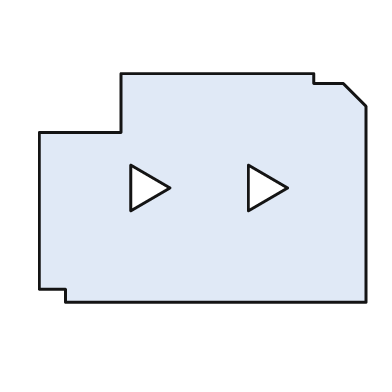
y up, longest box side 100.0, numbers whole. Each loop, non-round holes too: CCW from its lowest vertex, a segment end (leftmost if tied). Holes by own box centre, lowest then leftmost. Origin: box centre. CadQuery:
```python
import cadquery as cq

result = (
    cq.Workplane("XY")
    .moveTo(-42.0, -35.0)
    .lineTo(50.0, -35.0)
    .lineTo(50.0, 25.0)
    .lineTo(43.0, 32.0)
    .lineTo(34.0, 32.0)
    .lineTo(34.0, 35.0)
    .lineTo(-25.0, 35.0)
    .lineTo(-25.0, 17.0)
    .lineTo(-50.0, 17.0)
    .lineTo(-50.0, -31.0)
    .lineTo(-42.0, -31.0)
    .close()
    .moveTo(-22.0, -7.0)
    .lineTo(-10.0, 0.0)
    .lineTo(-22.0, 7.0)
    .close()
    .moveTo(14.0, -7.0)
    .lineTo(26.0, 0.0)
    .lineTo(14.0, 7.0)
    .close()
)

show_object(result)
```